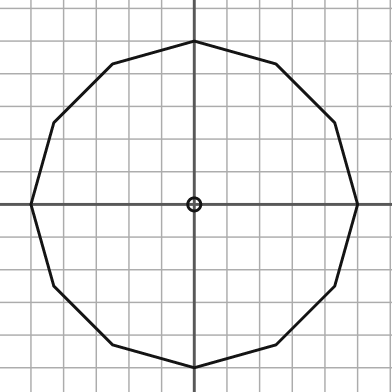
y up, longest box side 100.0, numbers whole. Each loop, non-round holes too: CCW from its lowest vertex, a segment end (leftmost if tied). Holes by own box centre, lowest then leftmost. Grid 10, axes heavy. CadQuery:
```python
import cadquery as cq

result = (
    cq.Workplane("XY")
    .moveTo(0.0, -50.0)
    .lineTo(25.0, -43.0)
    .lineTo(43.0, -25.0)
    .lineTo(50.0, 0.0)
    .lineTo(43.0, 25.0)
    .lineTo(25.0, 43.0)
    .lineTo(0.0, 50.0)
    .lineTo(-25.0, 43.0)
    .lineTo(-43.0, 25.0)
    .lineTo(-50.0, 0.0)
    .lineTo(-43.0, -25.0)
    .lineTo(-25.0, -43.0)
    .close()
    .moveTo(0.0, 0.0)
    .circle(2.0)
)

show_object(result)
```